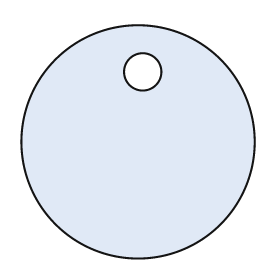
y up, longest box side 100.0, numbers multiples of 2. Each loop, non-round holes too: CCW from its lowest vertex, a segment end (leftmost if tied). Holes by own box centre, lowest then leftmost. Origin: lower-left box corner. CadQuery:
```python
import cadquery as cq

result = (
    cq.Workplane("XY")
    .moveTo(50.0, 50.0)
    .circle(50.0)
    .moveTo(52.0, 80.0)
    .circle(8.0)
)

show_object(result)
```